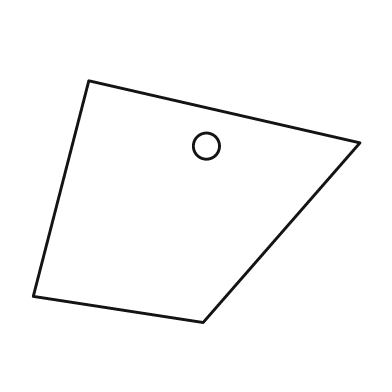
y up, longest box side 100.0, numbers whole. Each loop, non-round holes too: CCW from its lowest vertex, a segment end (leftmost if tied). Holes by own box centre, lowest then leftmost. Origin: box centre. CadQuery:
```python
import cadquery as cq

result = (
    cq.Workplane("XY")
    .moveTo(2.0, -37.0)
    .lineTo(50.0, 18.0)
    .lineTo(-33.0, 37.0)
    .lineTo(-50.0, -29.0)
    .close()
    .moveTo(3.0, 17.0)
    .circle(4.0)
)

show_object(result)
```